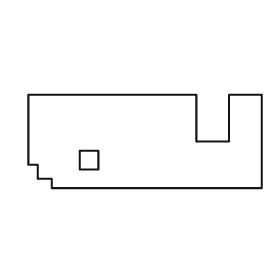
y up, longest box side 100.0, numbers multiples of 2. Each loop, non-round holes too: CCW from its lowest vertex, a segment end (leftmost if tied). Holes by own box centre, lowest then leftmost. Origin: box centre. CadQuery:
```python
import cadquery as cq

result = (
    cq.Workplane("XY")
    .moveTo(-40.0, -20.0)
    .lineTo(50.0, -20.0)
    .lineTo(50.0, 20.0)
    .lineTo(36.0, 20.0)
    .lineTo(36.0, 0.0)
    .lineTo(22.0, 0.0)
    .lineTo(22.0, 20.0)
    .lineTo(-50.0, 20.0)
    .lineTo(-50.0, -10.0)
    .lineTo(-46.0, -10.0)
    .lineTo(-46.0, -16.0)
    .lineTo(-40.0, -16.0)
    .close()
    .moveTo(-28.0, -12.0)
    .lineTo(-20.0, -12.0)
    .lineTo(-20.0, -4.0)
    .lineTo(-28.0, -4.0)
    .close()
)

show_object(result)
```